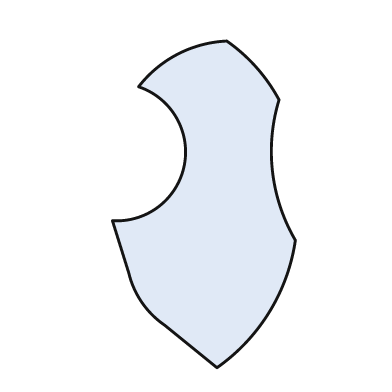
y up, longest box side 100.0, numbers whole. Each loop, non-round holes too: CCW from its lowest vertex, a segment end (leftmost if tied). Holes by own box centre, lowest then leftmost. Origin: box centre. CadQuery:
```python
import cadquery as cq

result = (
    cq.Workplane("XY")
    .moveTo(4.0, -50.0)
    .threePointArc((20.0, -33.0), (28.0, -11.0))
    .threePointArc((21.0, 10.0), (23.0, 32.0))
    .threePointArc((16.0, 42.0), (7.0, 50.0))
    .threePointArc((-8.0, 46.0), (-20.0, 36.0))
    .threePointArc((-6.0, 12.0), (-28.0, -5.0))
    .lineTo(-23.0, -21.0)
    .threePointArc((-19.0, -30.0), (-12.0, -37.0))
    .close()
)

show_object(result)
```